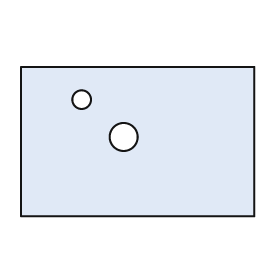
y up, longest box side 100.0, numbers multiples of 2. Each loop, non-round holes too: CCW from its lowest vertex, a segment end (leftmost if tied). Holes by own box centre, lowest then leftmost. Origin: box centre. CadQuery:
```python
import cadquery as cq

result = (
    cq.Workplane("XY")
    .moveTo(-50.0, -32.0)
    .lineTo(50.0, -32.0)
    .lineTo(50.0, 32.0)
    .lineTo(-50.0, 32.0)
    .close()
    .moveTo(-6.0, 2.0)
    .circle(6.0)
    .moveTo(-24.0, 18.0)
    .circle(4.0)
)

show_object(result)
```